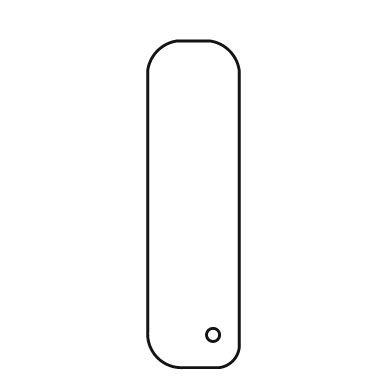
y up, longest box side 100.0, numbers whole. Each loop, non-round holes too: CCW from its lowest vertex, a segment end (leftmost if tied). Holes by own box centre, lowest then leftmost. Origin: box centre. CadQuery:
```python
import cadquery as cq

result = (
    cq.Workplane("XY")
    .moveTo(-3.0, -50.0)
    .lineTo(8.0, -50.0)
    .threePointArc((12.0, -48.0), (14.0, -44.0))
    .lineTo(14.0, 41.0)
    .threePointArc((11.0, 47.0), (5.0, 50.0))
    .lineTo(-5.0, 50.0)
    .threePointArc((-11.0, 47.0), (-14.0, 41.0))
    .lineTo(-14.0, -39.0)
    .threePointArc((-11.0, -47.0), (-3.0, -50.0))
    .close()
    .moveTo(6.0, -40.0)
    .circle(2.0)
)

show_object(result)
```